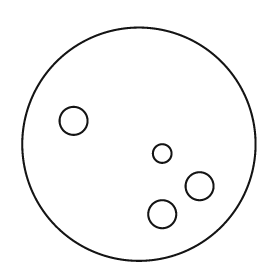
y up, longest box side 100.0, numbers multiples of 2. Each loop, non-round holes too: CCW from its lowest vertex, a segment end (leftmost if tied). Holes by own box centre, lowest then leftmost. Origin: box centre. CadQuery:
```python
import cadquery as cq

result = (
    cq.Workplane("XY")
    .moveTo(0.0, 0.0)
    .circle(50.0)
    .moveTo(10.0, -30.0)
    .circle(6.0)
    .moveTo(26.0, -18.0)
    .circle(6.0)
    .moveTo(10.0, -4.0)
    .circle(4.0)
    .moveTo(-28.0, 10.0)
    .circle(6.0)
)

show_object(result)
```